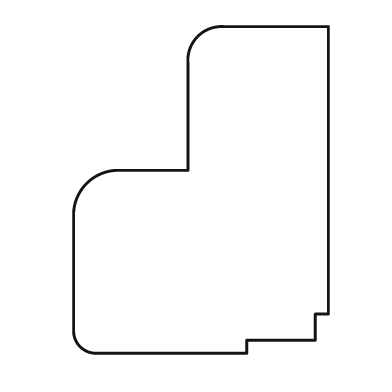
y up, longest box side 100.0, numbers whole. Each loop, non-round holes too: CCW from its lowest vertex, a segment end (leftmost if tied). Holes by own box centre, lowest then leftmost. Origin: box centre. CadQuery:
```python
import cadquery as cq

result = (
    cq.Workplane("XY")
    .moveTo(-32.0, -50.0)
    .lineTo(14.0, -50.0)
    .lineTo(14.0, -46.0)
    .lineTo(35.0, -46.0)
    .lineTo(35.0, -38.0)
    .lineTo(39.0, -38.0)
    .lineTo(39.0, 50.0)
    .lineTo(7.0, 50.0)
    .threePointArc((-1.0, 47.0), (-4.0, 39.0))
    .lineTo(-4.0, 6.0)
    .lineTo(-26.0, 6.0)
    .threePointArc((-35.0, 2.0), (-39.0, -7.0))
    .lineTo(-39.0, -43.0)
    .threePointArc((-37.0, -48.0), (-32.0, -50.0))
    .close()
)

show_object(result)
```